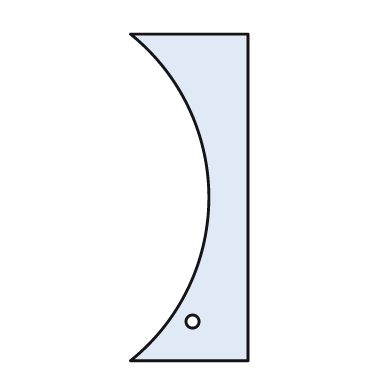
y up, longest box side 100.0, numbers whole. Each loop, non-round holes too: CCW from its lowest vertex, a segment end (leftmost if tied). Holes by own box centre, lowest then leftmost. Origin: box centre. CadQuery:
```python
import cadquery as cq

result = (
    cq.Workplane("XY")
    .moveTo(-18.0, -50.0)
    .lineTo(18.0, -50.0)
    .lineTo(18.0, 50.0)
    .lineTo(-18.0, 50.0)
    .threePointArc((6.0, 0.0), (-18.0, -50.0))
    .close()
    .moveTo(1.0, -38.0)
    .circle(2.0)
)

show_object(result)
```